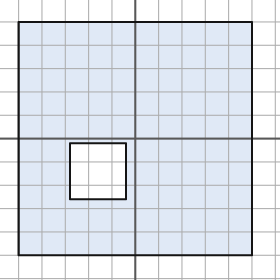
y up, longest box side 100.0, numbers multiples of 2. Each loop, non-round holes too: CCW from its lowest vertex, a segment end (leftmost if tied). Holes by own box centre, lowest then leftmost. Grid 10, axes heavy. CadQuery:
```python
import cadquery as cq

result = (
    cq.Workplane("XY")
    .moveTo(-50.0, -50.0)
    .lineTo(50.0, -50.0)
    .lineTo(50.0, 50.0)
    .lineTo(-50.0, 50.0)
    .close()
    .moveTo(-28.0, -26.0)
    .lineTo(-4.0, -26.0)
    .lineTo(-4.0, -2.0)
    .lineTo(-28.0, -2.0)
    .close()
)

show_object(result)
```